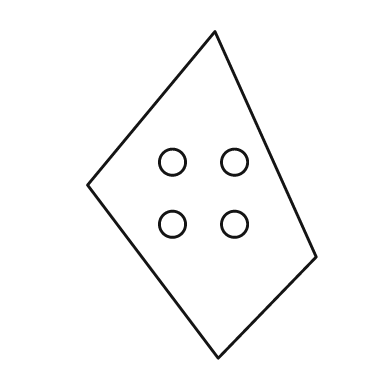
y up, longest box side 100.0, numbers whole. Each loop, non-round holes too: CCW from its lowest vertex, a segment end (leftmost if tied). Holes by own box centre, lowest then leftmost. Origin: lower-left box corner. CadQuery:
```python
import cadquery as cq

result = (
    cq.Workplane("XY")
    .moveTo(40.0, 0.0)
    .lineTo(70.0, 31.0)
    .lineTo(39.0, 100.0)
    .lineTo(0.0, 53.0)
    .close()
    .moveTo(26.0, 41.0)
    .circle(4.0)
    .moveTo(45.0, 41.0)
    .circle(4.0)
    .moveTo(26.0, 60.0)
    .circle(4.0)
    .moveTo(45.0, 60.0)
    .circle(4.0)
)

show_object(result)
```